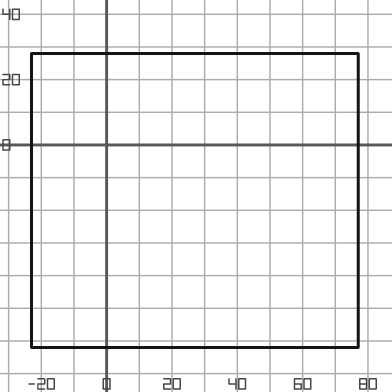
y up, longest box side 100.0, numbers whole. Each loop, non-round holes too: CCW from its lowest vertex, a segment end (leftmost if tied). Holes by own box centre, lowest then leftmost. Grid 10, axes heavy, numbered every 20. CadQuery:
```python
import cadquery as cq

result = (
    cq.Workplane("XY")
    .moveTo(-23.0, -62.0)
    .lineTo(77.0, -62.0)
    .lineTo(77.0, 28.0)
    .lineTo(-23.0, 28.0)
    .close()
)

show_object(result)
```